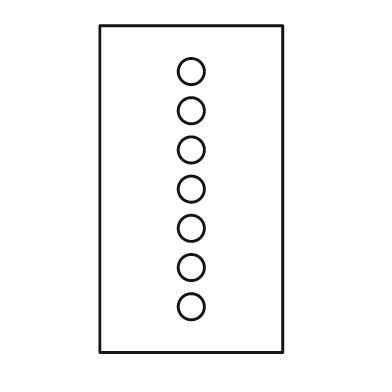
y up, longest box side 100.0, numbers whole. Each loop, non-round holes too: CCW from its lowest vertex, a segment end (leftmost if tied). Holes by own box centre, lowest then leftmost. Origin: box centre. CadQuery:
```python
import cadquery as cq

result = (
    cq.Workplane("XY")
    .moveTo(-28.0, -50.0)
    .lineTo(28.0, -50.0)
    .lineTo(28.0, 50.0)
    .lineTo(-28.0, 50.0)
    .close()
    .moveTo(0.0, -36.0)
    .circle(4.0)
    .moveTo(0.0, -24.0)
    .circle(4.0)
    .moveTo(0.0, -12.0)
    .circle(4.0)
    .moveTo(0.0, 0.0)
    .circle(4.0)
    .moveTo(0.0, 12.0)
    .circle(4.0)
    .moveTo(0.0, 24.0)
    .circle(4.0)
    .moveTo(0.0, 36.0)
    .circle(4.0)
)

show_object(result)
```